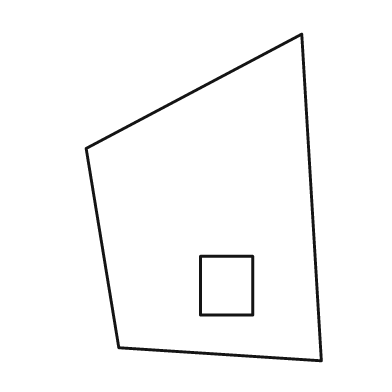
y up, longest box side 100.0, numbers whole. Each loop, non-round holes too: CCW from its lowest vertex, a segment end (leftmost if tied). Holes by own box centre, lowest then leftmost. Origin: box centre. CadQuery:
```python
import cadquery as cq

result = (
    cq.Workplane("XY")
    .moveTo(36.0, -50.0)
    .lineTo(30.0, 50.0)
    .lineTo(-36.0, 15.0)
    .lineTo(-26.0, -46.0)
    .close()
    .moveTo(-1.0, -36.0)
    .lineTo(15.0, -36.0)
    .lineTo(15.0, -18.0)
    .lineTo(-1.0, -18.0)
    .close()
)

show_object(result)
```